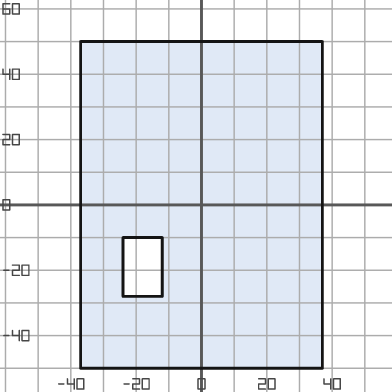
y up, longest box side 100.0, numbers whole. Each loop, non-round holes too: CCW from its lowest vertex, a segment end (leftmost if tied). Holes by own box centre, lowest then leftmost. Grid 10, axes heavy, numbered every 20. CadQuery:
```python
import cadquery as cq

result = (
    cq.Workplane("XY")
    .moveTo(-37.0, -50.0)
    .lineTo(37.0, -50.0)
    .lineTo(37.0, 50.0)
    .lineTo(-37.0, 50.0)
    .close()
    .moveTo(-24.0, -28.0)
    .lineTo(-12.0, -28.0)
    .lineTo(-12.0, -10.0)
    .lineTo(-24.0, -10.0)
    .close()
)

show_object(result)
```